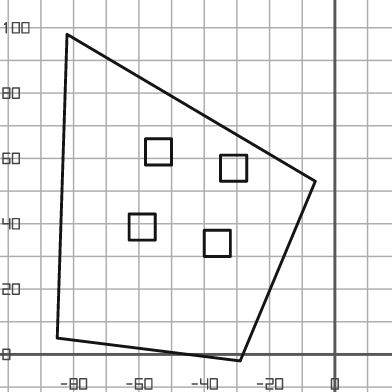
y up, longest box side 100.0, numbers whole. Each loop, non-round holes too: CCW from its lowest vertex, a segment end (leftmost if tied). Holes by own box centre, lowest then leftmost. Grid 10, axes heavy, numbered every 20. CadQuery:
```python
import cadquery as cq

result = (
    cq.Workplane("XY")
    .moveTo(-29.0, -2.0)
    .lineTo(-6.0, 53.0)
    .lineTo(-82.0, 98.0)
    .lineTo(-85.0, 5.0)
    .close()
    .moveTo(-40.0, 30.0)
    .lineTo(-32.0, 30.0)
    .lineTo(-32.0, 38.0)
    .lineTo(-40.0, 38.0)
    .close()
    .moveTo(-63.0, 35.0)
    .lineTo(-55.0, 35.0)
    .lineTo(-55.0, 43.0)
    .lineTo(-63.0, 43.0)
    .close()
    .moveTo(-35.0, 53.0)
    .lineTo(-27.0, 53.0)
    .lineTo(-27.0, 61.0)
    .lineTo(-35.0, 61.0)
    .close()
    .moveTo(-58.0, 58.0)
    .lineTo(-50.0, 58.0)
    .lineTo(-50.0, 66.0)
    .lineTo(-58.0, 66.0)
    .close()
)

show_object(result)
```